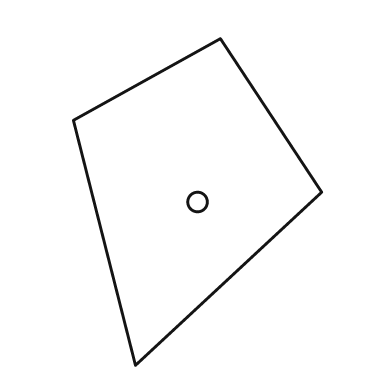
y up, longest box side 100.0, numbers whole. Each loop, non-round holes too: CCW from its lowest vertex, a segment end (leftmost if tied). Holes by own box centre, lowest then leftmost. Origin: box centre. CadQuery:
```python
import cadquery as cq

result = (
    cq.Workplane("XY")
    .moveTo(-19.0, -50.0)
    .lineTo(38.0, 3.0)
    .lineTo(7.0, 50.0)
    .lineTo(-38.0, 25.0)
    .close()
    .moveTo(0.0, 0.0)
    .circle(3.0)
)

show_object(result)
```